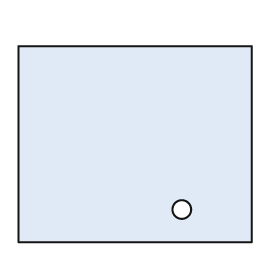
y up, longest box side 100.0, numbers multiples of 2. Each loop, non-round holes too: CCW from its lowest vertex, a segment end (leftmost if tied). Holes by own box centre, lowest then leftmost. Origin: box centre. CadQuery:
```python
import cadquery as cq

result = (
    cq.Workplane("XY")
    .moveTo(-50.0, -42.0)
    .lineTo(50.0, -42.0)
    .lineTo(50.0, 42.0)
    .lineTo(-50.0, 42.0)
    .close()
    .moveTo(20.0, -28.0)
    .circle(4.0)
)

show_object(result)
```